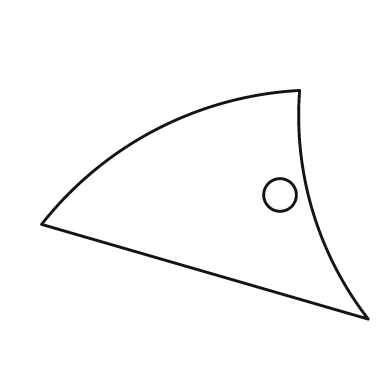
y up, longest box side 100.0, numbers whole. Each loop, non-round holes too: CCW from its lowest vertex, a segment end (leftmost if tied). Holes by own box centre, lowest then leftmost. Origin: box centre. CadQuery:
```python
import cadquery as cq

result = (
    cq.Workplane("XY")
    .moveTo(50.0, -35.0)
    .threePointArc((33.0, -2.0), (29.0, 35.0))
    .threePointArc((-15.0, 23.0), (-50.0, -6.0))
    .close()
    .moveTo(23.0, 3.0)
    .circle(5.0)
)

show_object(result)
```